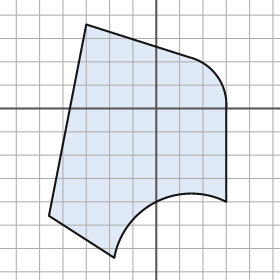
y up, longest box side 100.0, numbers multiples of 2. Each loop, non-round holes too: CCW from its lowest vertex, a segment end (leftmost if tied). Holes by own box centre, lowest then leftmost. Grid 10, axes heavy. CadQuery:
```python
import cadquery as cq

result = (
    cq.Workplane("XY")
    .moveTo(-18.0, -64.0)
    .threePointArc((0.0, -40.0), (30.0, -40.0))
    .lineTo(30.0, 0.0)
    .threePointArc((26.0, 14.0), (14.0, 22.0))
    .lineTo(-30.0, 36.0)
    .lineTo(-46.0, -46.0)
    .close()
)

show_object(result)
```